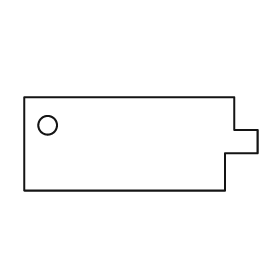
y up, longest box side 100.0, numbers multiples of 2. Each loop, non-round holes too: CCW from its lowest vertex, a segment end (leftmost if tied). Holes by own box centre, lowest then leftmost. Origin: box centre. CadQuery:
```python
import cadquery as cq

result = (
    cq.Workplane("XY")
    .moveTo(-50.0, -20.0)
    .lineTo(36.0, -20.0)
    .lineTo(36.0, -4.0)
    .lineTo(50.0, -4.0)
    .lineTo(50.0, 6.0)
    .lineTo(40.0, 6.0)
    .lineTo(40.0, 20.0)
    .lineTo(-50.0, 20.0)
    .close()
    .moveTo(-40.0, 8.0)
    .circle(4.0)
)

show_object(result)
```